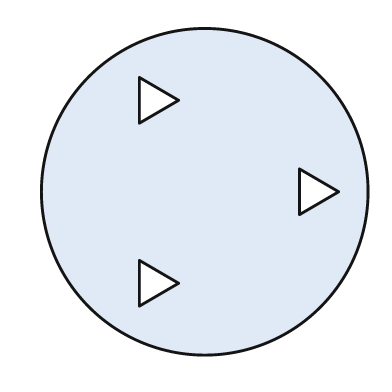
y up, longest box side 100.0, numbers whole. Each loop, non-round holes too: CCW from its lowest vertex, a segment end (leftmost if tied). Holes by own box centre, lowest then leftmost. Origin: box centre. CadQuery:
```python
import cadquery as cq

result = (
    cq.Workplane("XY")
    .moveTo(0.0, 0.0)
    .circle(50.0)
    .moveTo(-20.0, -35.0)
    .lineTo(-8.0, -28.0)
    .lineTo(-20.0, -21.0)
    .close()
    .moveTo(29.0, -7.0)
    .lineTo(41.0, 0.0)
    .lineTo(29.0, 7.0)
    .close()
    .moveTo(-20.0, 21.0)
    .lineTo(-8.0, 28.0)
    .lineTo(-20.0, 35.0)
    .close()
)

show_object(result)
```